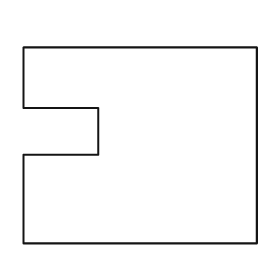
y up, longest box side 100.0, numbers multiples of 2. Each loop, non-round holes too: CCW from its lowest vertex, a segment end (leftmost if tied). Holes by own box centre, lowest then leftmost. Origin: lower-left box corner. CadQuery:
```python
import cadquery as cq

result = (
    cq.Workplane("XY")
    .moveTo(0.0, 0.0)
    .lineTo(100.0, 0.0)
    .lineTo(100.0, 84.0)
    .lineTo(0.0, 84.0)
    .lineTo(0.0, 58.0)
    .lineTo(32.0, 58.0)
    .lineTo(32.0, 38.0)
    .lineTo(0.0, 38.0)
    .close()
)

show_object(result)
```